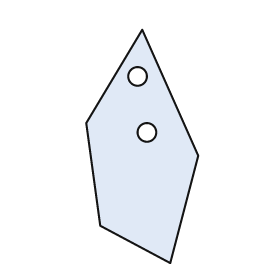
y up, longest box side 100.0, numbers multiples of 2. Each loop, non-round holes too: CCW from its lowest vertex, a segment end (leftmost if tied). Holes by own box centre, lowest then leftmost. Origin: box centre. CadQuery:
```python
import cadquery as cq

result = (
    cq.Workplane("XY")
    .moveTo(12.0, -50.0)
    .lineTo(24.0, -4.0)
    .lineTo(0.0, 50.0)
    .lineTo(-24.0, 10.0)
    .lineTo(-18.0, -34.0)
    .close()
    .moveTo(2.0, 6.0)
    .circle(4.0)
    .moveTo(-2.0, 30.0)
    .circle(4.0)
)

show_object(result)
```